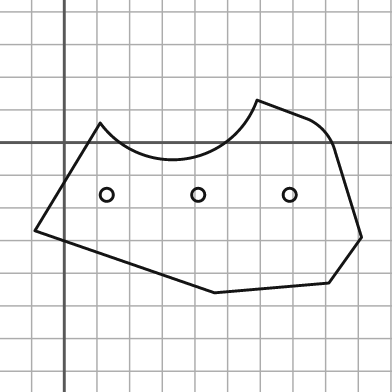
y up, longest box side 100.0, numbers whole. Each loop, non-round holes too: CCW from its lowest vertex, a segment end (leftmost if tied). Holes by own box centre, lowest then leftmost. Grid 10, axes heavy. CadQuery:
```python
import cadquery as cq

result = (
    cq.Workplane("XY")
    .moveTo(46.0, -46.0)
    .lineTo(81.0, -43.0)
    .lineTo(91.0, -29.0)
    .lineTo(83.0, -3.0)
    .threePointArc((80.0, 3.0), (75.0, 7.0))
    .lineTo(59.0, 13.0)
    .threePointArc((37.0, -5.0), (11.0, 6.0))
    .lineTo(-9.0, -27.0)
    .close()
    .moveTo(13.0, -16.0)
    .circle(2.0)
    .moveTo(41.0, -16.0)
    .circle(2.0)
    .moveTo(69.0, -16.0)
    .circle(2.0)
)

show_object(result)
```